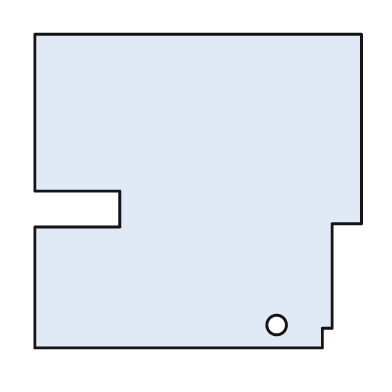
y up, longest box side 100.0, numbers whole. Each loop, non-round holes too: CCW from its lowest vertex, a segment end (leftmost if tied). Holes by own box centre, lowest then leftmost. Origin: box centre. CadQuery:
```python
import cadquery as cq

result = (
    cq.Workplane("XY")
    .moveTo(-50.0, -48.0)
    .lineTo(38.0, -48.0)
    .lineTo(38.0, -42.0)
    .lineTo(41.0, -42.0)
    .lineTo(41.0, -10.0)
    .lineTo(50.0, -10.0)
    .lineTo(50.0, 48.0)
    .lineTo(-50.0, 48.0)
    .lineTo(-50.0, 0.0)
    .lineTo(-24.0, 0.0)
    .lineTo(-24.0, -11.0)
    .lineTo(-50.0, -11.0)
    .close()
    .moveTo(24.0, -41.0)
    .circle(3.0)
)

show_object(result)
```